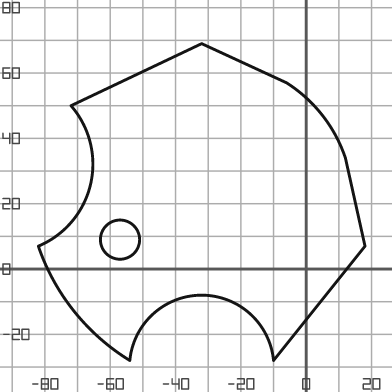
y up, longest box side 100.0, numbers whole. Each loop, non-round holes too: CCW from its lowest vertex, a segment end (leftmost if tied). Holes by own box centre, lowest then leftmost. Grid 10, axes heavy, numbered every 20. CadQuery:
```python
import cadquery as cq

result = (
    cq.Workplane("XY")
    .moveTo(-54.0, -28.0)
    .threePointArc((-32.0, -8.0), (-10.0, -28.0))
    .lineTo(18.0, 7.0)
    .lineTo(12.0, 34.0)
    .threePointArc((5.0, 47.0), (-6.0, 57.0))
    .lineTo(-32.0, 69.0)
    .lineTo(-72.0, 50.0)
    .threePointArc((-66.0, 26.0), (-82.0, 7.0))
    .threePointArc((-71.0, -13.0), (-54.0, -28.0))
    .close()
    .moveTo(-57.0, 9.0)
    .circle(6.0)
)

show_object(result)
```